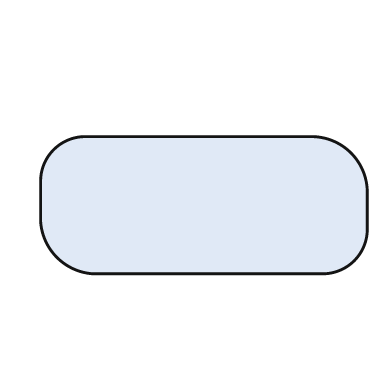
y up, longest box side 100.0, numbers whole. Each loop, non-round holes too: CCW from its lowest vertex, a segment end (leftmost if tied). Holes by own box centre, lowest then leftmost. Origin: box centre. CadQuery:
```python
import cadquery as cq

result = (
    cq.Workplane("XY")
    .moveTo(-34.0, -21.0)
    .lineTo(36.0, -21.0)
    .threePointArc((46.0, -17.0), (50.0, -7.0))
    .lineTo(50.0, 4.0)
    .threePointArc((45.0, 16.0), (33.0, 21.0))
    .lineTo(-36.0, 21.0)
    .threePointArc((-46.0, 17.0), (-50.0, 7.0))
    .lineTo(-50.0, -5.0)
    .threePointArc((-45.0, -16.0), (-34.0, -21.0))
    .close()
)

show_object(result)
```